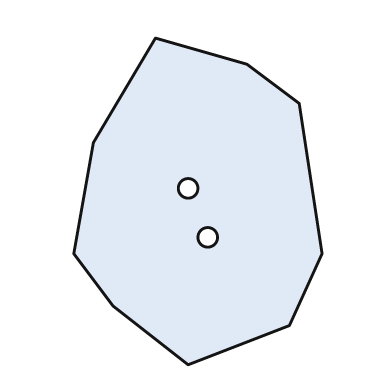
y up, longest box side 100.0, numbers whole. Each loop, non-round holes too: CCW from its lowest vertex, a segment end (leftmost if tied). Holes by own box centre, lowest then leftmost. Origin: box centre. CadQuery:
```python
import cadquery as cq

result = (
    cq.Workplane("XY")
    .moveTo(-3.0, -50.0)
    .lineTo(28.0, -38.0)
    .lineTo(38.0, -16.0)
    .lineTo(31.0, 30.0)
    .lineTo(15.0, 42.0)
    .lineTo(-13.0, 50.0)
    .lineTo(-32.0, 18.0)
    .lineTo(-38.0, -16.0)
    .lineTo(-26.0, -32.0)
    .close()
    .moveTo(3.0, -11.0)
    .circle(3.0)
    .moveTo(-3.0, 4.0)
    .circle(3.0)
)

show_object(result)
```